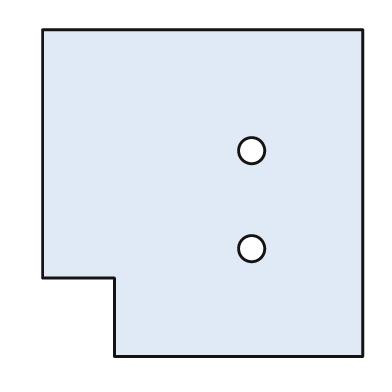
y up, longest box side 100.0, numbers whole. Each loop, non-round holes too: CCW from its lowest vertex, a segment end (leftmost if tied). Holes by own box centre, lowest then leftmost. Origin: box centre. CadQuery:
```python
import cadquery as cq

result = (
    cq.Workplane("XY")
    .moveTo(-27.0, -50.0)
    .lineTo(49.0, -50.0)
    .lineTo(49.0, 50.0)
    .lineTo(-49.0, 50.0)
    .lineTo(-49.0, -26.0)
    .lineTo(-27.0, -26.0)
    .close()
    .moveTo(15.0, -17.0)
    .circle(4.0)
    .moveTo(15.0, 13.0)
    .circle(4.0)
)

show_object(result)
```